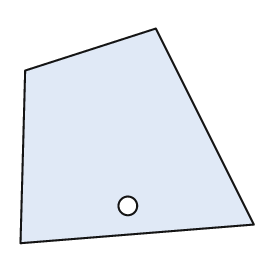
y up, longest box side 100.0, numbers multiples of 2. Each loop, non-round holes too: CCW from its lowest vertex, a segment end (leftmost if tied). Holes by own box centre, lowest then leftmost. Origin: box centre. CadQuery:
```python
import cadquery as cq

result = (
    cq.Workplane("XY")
    .moveTo(-50.0, -46.0)
    .lineTo(50.0, -38.0)
    .lineTo(8.0, 46.0)
    .lineTo(-48.0, 28.0)
    .close()
    .moveTo(-4.0, -30.0)
    .circle(4.0)
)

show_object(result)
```